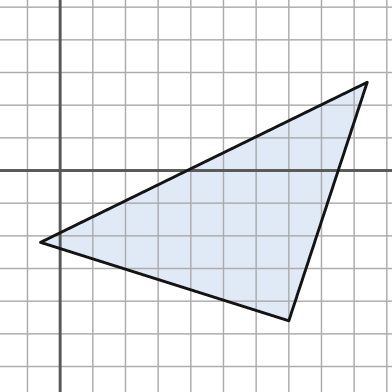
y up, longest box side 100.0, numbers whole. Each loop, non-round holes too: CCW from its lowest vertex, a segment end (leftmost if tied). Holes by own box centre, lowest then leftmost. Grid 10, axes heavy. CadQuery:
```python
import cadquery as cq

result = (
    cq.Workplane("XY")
    .moveTo(70.0, -46.0)
    .lineTo(94.0, 27.0)
    .lineTo(-6.0, -22.0)
    .close()
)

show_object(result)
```